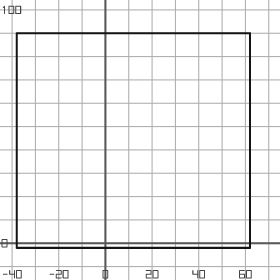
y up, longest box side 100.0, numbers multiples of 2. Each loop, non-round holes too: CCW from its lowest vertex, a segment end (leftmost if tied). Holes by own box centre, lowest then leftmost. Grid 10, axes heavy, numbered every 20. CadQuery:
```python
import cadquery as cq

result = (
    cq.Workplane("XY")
    .moveTo(-38.0, -2.0)
    .lineTo(62.0, -2.0)
    .lineTo(62.0, 90.0)
    .lineTo(-38.0, 90.0)
    .close()
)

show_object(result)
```